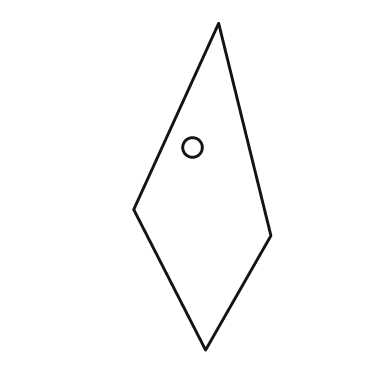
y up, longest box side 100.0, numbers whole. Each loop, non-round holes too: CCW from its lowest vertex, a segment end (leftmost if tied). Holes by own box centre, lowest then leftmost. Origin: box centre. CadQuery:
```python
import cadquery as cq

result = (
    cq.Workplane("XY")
    .moveTo(1.0, -50.0)
    .lineTo(21.0, -15.0)
    .lineTo(5.0, 50.0)
    .lineTo(-21.0, -7.0)
    .close()
    .moveTo(-3.0, 12.0)
    .circle(3.0)
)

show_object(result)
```